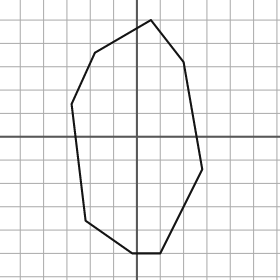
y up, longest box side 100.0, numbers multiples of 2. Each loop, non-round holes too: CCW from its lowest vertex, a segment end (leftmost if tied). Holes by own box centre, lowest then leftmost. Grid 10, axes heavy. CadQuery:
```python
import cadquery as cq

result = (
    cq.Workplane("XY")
    .moveTo(-2.0, -50.0)
    .lineTo(10.0, -50.0)
    .lineTo(28.0, -14.0)
    .lineTo(20.0, 32.0)
    .lineTo(6.0, 50.0)
    .lineTo(-18.0, 36.0)
    .lineTo(-28.0, 14.0)
    .lineTo(-22.0, -36.0)
    .close()
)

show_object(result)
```